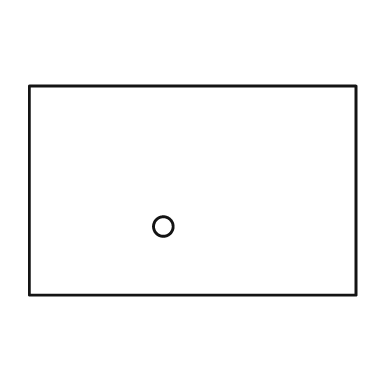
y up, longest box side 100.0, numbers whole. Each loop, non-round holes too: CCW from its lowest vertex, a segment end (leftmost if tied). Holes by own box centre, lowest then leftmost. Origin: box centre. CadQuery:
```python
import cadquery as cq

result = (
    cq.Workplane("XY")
    .moveTo(-50.0, -32.0)
    .lineTo(50.0, -32.0)
    .lineTo(50.0, 32.0)
    .lineTo(-50.0, 32.0)
    .close()
    .moveTo(-9.0, -11.0)
    .circle(3.0)
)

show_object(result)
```